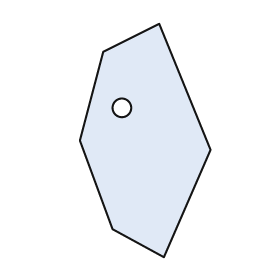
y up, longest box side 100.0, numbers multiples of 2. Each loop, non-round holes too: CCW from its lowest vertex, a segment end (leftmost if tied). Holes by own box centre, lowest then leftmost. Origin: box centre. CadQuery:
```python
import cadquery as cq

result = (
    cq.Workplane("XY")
    .moveTo(8.0, -50.0)
    .lineTo(28.0, -4.0)
    .lineTo(6.0, 50.0)
    .lineTo(-18.0, 38.0)
    .lineTo(-28.0, 0.0)
    .lineTo(-14.0, -38.0)
    .close()
    .moveTo(-10.0, 14.0)
    .circle(4.0)
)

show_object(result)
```